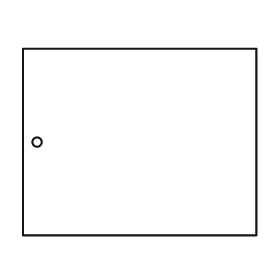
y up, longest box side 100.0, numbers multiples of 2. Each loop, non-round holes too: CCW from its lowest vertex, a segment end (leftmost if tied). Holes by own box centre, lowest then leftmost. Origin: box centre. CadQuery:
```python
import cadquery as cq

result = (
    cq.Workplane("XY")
    .moveTo(-50.0, -40.0)
    .lineTo(50.0, -40.0)
    .lineTo(50.0, 40.0)
    .lineTo(-50.0, 40.0)
    .close()
    .moveTo(-44.0, 0.0)
    .circle(2.0)
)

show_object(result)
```